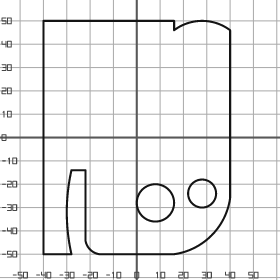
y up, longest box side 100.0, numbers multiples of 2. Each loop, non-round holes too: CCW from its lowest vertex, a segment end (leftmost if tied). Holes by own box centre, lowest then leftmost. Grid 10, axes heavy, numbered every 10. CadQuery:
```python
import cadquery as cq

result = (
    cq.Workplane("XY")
    .moveTo(-40.0, -50.0)
    .lineTo(-28.0, -50.0)
    .threePointArc((-30.0, -32.0), (-28.0, -14.0))
    .lineTo(-22.0, -14.0)
    .lineTo(-22.0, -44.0)
    .threePointArc((-20.0, -48.0), (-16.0, -50.0))
    .lineTo(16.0, -50.0)
    .threePointArc((32.0, -42.0), (40.0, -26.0))
    .lineTo(40.0, 46.0)
    .threePointArc((28.0, 50.0), (16.0, 46.0))
    .lineTo(16.0, 50.0)
    .lineTo(-40.0, 50.0)
    .close()
    .moveTo(8.0, -28.0)
    .circle(8.0)
    .moveTo(28.0, -24.0)
    .circle(6.0)
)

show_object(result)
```